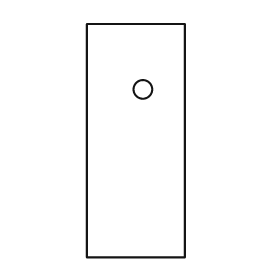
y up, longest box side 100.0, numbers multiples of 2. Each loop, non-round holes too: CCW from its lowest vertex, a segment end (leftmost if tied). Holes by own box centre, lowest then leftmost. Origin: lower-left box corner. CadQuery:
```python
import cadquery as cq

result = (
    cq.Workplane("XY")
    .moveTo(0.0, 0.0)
    .lineTo(42.0, 0.0)
    .lineTo(42.0, 100.0)
    .lineTo(0.0, 100.0)
    .close()
    .moveTo(24.0, 72.0)
    .circle(4.0)
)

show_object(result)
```